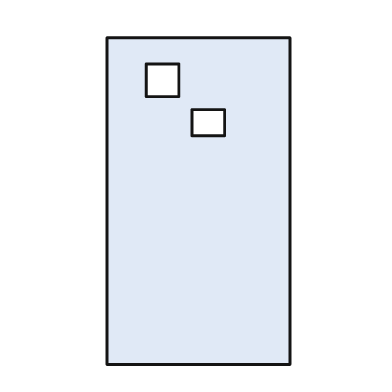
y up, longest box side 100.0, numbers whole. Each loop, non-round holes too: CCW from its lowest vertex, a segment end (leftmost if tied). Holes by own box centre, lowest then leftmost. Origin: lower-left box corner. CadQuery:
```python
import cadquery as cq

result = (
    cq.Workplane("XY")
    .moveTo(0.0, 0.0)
    .lineTo(56.0, 0.0)
    .lineTo(56.0, 100.0)
    .lineTo(0.0, 100.0)
    .close()
    .moveTo(26.0, 70.0)
    .lineTo(36.0, 70.0)
    .lineTo(36.0, 78.0)
    .lineTo(26.0, 78.0)
    .close()
    .moveTo(12.0, 82.0)
    .lineTo(22.0, 82.0)
    .lineTo(22.0, 92.0)
    .lineTo(12.0, 92.0)
    .close()
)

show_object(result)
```